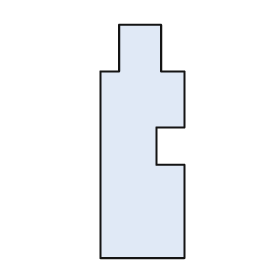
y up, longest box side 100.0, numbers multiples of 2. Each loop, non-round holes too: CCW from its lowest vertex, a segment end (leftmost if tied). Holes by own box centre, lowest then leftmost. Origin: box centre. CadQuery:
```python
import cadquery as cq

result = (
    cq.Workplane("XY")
    .moveTo(-18.0, -50.0)
    .lineTo(18.0, -50.0)
    .lineTo(18.0, -10.0)
    .lineTo(6.0, -10.0)
    .lineTo(6.0, 6.0)
    .lineTo(18.0, 6.0)
    .lineTo(18.0, 30.0)
    .lineTo(8.0, 30.0)
    .lineTo(8.0, 50.0)
    .lineTo(-10.0, 50.0)
    .lineTo(-10.0, 30.0)
    .lineTo(-18.0, 30.0)
    .close()
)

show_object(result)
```